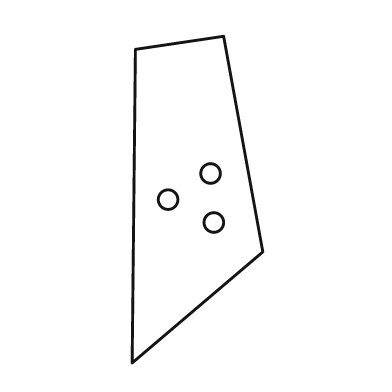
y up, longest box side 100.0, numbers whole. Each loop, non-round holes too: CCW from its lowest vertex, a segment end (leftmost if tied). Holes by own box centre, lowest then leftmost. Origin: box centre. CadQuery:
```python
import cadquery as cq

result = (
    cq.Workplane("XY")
    .moveTo(-20.0, -50.0)
    .lineTo(20.0, -16.0)
    .lineTo(8.0, 50.0)
    .lineTo(-19.0, 46.0)
    .close()
    .moveTo(5.0, -7.0)
    .circle(3.0)
    .moveTo(-9.0, 0.0)
    .circle(3.0)
    .moveTo(4.0, 8.0)
    .circle(3.0)
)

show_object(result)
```